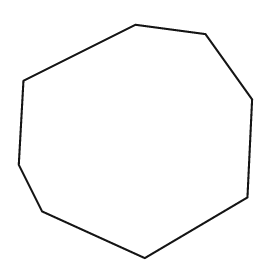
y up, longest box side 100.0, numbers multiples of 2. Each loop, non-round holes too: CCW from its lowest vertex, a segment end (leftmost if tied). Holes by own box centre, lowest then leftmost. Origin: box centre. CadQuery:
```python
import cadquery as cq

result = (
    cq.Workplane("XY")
    .moveTo(4.0, -50.0)
    .lineTo(48.0, -24.0)
    .lineTo(50.0, 18.0)
    .lineTo(30.0, 46.0)
    .lineTo(0.0, 50.0)
    .lineTo(-48.0, 26.0)
    .lineTo(-50.0, -10.0)
    .lineTo(-40.0, -30.0)
    .close()
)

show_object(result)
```